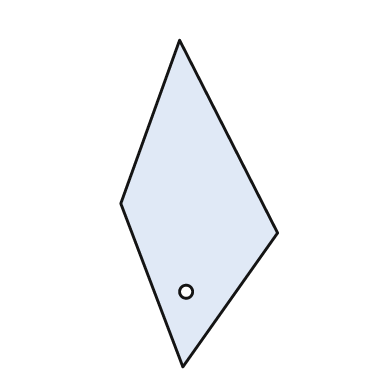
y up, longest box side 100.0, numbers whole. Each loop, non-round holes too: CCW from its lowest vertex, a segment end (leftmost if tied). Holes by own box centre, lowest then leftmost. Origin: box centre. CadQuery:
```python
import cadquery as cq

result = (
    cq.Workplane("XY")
    .moveTo(-5.0, -50.0)
    .lineTo(24.0, -9.0)
    .lineTo(-6.0, 50.0)
    .lineTo(-24.0, 0.0)
    .close()
    .moveTo(-4.0, -27.0)
    .circle(2.0)
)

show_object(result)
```